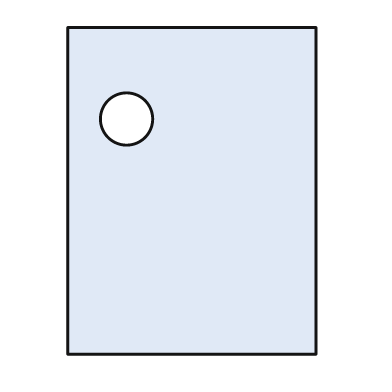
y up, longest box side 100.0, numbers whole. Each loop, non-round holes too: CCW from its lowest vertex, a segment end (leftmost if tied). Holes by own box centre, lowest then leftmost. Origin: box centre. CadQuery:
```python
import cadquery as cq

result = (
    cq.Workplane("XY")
    .moveTo(-38.0, -50.0)
    .lineTo(38.0, -50.0)
    .lineTo(38.0, 50.0)
    .lineTo(-38.0, 50.0)
    .close()
    .moveTo(-20.0, 22.0)
    .circle(8.0)
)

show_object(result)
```